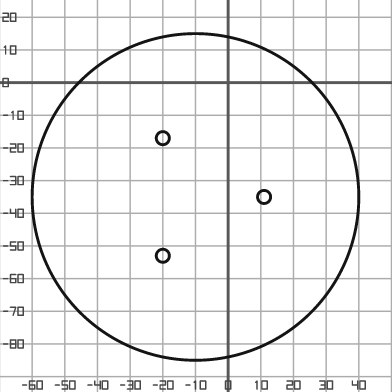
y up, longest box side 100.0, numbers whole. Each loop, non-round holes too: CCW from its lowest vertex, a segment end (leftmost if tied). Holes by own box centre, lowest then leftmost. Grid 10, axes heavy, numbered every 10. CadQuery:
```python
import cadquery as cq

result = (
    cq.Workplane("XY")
    .moveTo(-10.0, -35.0)
    .circle(50.0)
    .moveTo(-20.0, -53.0)
    .circle(2.0)
    .moveTo(11.0, -35.0)
    .circle(2.0)
    .moveTo(-20.0, -17.0)
    .circle(2.0)
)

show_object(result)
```